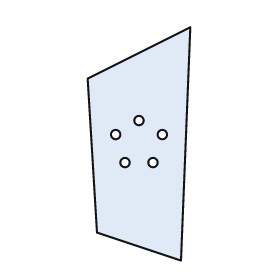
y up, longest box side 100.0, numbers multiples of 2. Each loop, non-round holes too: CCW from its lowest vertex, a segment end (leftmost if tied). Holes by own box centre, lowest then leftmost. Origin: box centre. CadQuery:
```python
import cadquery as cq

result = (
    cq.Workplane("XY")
    .moveTo(18.0, -50.0)
    .lineTo(22.0, 50.0)
    .lineTo(-22.0, 28.0)
    .lineTo(-18.0, -38.0)
    .close()
    .moveTo(-6.0, -8.0)
    .circle(2.0)
    .moveTo(6.0, -8.0)
    .circle(2.0)
    .moveTo(-10.0, 4.0)
    .circle(2.0)
    .moveTo(10.0, 4.0)
    .circle(2.0)
    .moveTo(0.0, 10.0)
    .circle(2.0)
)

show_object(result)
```